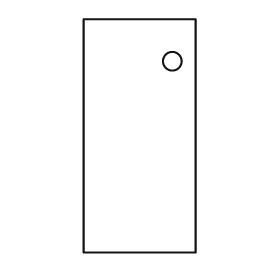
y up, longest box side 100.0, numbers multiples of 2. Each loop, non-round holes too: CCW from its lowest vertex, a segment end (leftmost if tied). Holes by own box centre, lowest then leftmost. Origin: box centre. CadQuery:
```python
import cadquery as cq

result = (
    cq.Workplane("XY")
    .moveTo(-24.0, -50.0)
    .lineTo(24.0, -50.0)
    .lineTo(24.0, 50.0)
    .lineTo(-24.0, 50.0)
    .close()
    .moveTo(14.0, 32.0)
    .circle(4.0)
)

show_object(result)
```